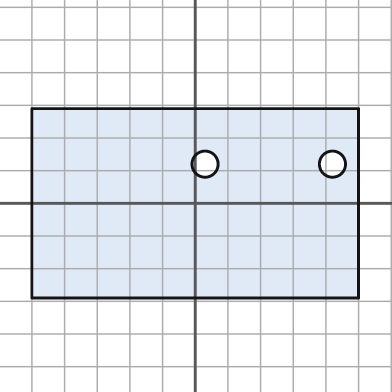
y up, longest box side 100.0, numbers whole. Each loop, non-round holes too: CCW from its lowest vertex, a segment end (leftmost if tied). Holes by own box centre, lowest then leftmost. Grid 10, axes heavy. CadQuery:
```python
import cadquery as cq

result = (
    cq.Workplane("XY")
    .moveTo(-50.0, -29.0)
    .lineTo(50.0, -29.0)
    .lineTo(50.0, 29.0)
    .lineTo(-50.0, 29.0)
    .close()
    .moveTo(3.0, 12.0)
    .circle(4.0)
    .moveTo(42.0, 12.0)
    .circle(4.0)
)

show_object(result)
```